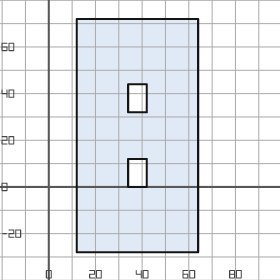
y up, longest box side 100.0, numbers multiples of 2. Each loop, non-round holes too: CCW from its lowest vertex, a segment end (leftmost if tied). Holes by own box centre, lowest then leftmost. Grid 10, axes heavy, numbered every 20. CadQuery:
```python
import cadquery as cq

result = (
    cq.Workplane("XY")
    .moveTo(12.0, -28.0)
    .lineTo(64.0, -28.0)
    .lineTo(64.0, 72.0)
    .lineTo(12.0, 72.0)
    .close()
    .moveTo(34.0, 0.0)
    .lineTo(42.0, 0.0)
    .lineTo(42.0, 12.0)
    .lineTo(34.0, 12.0)
    .close()
    .moveTo(34.0, 32.0)
    .lineTo(42.0, 32.0)
    .lineTo(42.0, 44.0)
    .lineTo(34.0, 44.0)
    .close()
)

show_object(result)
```